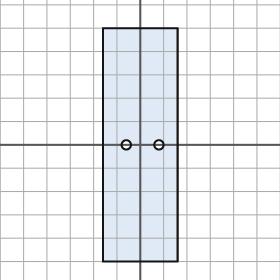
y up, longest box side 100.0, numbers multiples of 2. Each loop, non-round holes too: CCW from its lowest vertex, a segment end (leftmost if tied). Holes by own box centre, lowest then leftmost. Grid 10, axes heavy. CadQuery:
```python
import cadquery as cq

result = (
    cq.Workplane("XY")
    .moveTo(-16.0, -50.0)
    .lineTo(16.0, -50.0)
    .lineTo(16.0, 50.0)
    .lineTo(-16.0, 50.0)
    .close()
    .moveTo(-6.0, 0.0)
    .circle(2.0)
    .moveTo(8.0, 0.0)
    .circle(2.0)
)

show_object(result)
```